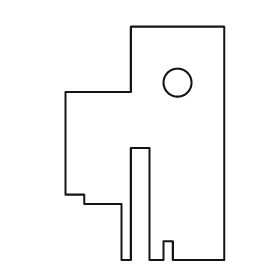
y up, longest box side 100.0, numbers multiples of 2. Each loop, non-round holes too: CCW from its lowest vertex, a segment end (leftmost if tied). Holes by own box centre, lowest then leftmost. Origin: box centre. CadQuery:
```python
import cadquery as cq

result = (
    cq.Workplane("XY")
    .moveTo(-10.0, -50.0)
    .lineTo(-6.0, -50.0)
    .lineTo(-6.0, -2.0)
    .lineTo(2.0, -2.0)
    .lineTo(2.0, -50.0)
    .lineTo(8.0, -50.0)
    .lineTo(8.0, -42.0)
    .lineTo(12.0, -42.0)
    .lineTo(12.0, -50.0)
    .lineTo(34.0, -50.0)
    .lineTo(34.0, 50.0)
    .lineTo(-6.0, 50.0)
    .lineTo(-6.0, 22.0)
    .lineTo(-34.0, 22.0)
    .lineTo(-34.0, -22.0)
    .lineTo(-26.0, -22.0)
    .lineTo(-26.0, -26.0)
    .lineTo(-10.0, -26.0)
    .close()
    .moveTo(14.0, 26.0)
    .circle(6.0)
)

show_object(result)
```